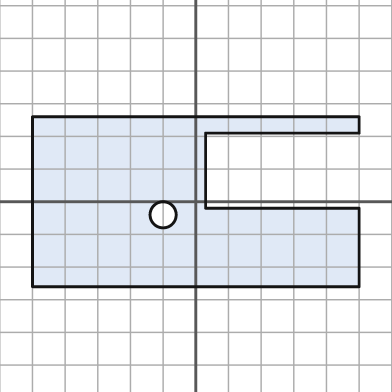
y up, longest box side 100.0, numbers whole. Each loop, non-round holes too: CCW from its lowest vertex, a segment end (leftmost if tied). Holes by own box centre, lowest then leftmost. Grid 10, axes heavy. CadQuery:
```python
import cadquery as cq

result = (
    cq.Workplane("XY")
    .moveTo(-50.0, -26.0)
    .lineTo(50.0, -26.0)
    .lineTo(50.0, -2.0)
    .lineTo(3.0, -2.0)
    .lineTo(3.0, 21.0)
    .lineTo(50.0, 21.0)
    .lineTo(50.0, 26.0)
    .lineTo(-50.0, 26.0)
    .close()
    .moveTo(-10.0, -4.0)
    .circle(4.0)
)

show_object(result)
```